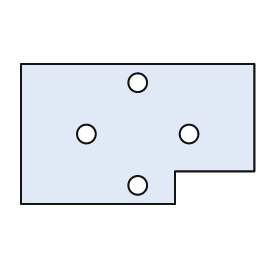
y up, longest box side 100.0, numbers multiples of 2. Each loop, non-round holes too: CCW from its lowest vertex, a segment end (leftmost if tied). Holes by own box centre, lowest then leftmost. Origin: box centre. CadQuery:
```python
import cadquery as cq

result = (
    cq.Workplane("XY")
    .moveTo(-50.0, -30.0)
    .lineTo(16.0, -30.0)
    .lineTo(16.0, -16.0)
    .lineTo(50.0, -16.0)
    .lineTo(50.0, 30.0)
    .lineTo(-50.0, 30.0)
    .close()
    .moveTo(0.0, -22.0)
    .circle(4.0)
    .moveTo(-22.0, 0.0)
    .circle(4.0)
    .moveTo(22.0, 0.0)
    .circle(4.0)
    .moveTo(0.0, 22.0)
    .circle(4.0)
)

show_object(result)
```